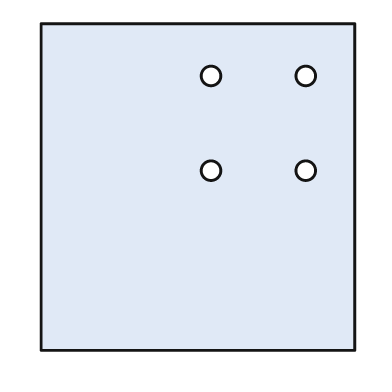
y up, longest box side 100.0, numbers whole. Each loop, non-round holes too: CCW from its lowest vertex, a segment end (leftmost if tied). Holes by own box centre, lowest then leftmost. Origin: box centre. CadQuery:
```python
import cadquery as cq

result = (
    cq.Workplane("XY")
    .moveTo(-48.0, -50.0)
    .lineTo(48.0, -50.0)
    .lineTo(48.0, 50.0)
    .lineTo(-48.0, 50.0)
    .close()
    .moveTo(4.0, 5.0)
    .circle(3.0)
    .moveTo(33.0, 5.0)
    .circle(3.0)
    .moveTo(4.0, 34.0)
    .circle(3.0)
    .moveTo(33.0, 34.0)
    .circle(3.0)
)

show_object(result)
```